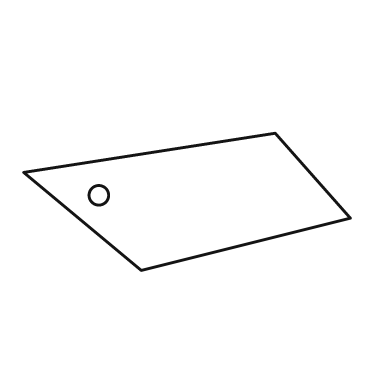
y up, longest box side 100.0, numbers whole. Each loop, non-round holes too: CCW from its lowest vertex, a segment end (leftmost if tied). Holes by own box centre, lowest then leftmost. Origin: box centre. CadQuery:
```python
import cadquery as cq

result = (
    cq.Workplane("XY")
    .moveTo(-14.0, -21.0)
    .lineTo(50.0, -5.0)
    .lineTo(27.0, 21.0)
    .lineTo(-50.0, 9.0)
    .close()
    .moveTo(-27.0, 2.0)
    .circle(3.0)
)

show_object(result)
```